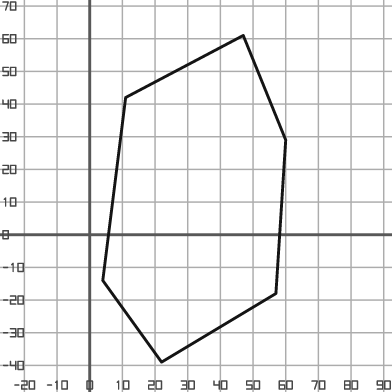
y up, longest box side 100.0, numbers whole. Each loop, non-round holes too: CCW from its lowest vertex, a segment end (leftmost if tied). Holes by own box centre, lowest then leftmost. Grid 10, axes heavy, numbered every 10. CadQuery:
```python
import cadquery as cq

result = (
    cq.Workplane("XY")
    .moveTo(22.0, -39.0)
    .lineTo(57.0, -18.0)
    .lineTo(60.0, 29.0)
    .lineTo(47.0, 61.0)
    .lineTo(11.0, 42.0)
    .lineTo(4.0, -14.0)
    .close()
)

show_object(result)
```